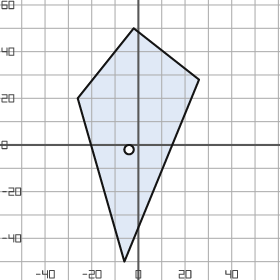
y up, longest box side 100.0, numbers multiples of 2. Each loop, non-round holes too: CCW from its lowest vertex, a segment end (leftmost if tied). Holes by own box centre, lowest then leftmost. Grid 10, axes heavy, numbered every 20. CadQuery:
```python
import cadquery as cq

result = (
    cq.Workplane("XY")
    .moveTo(-6.0, -50.0)
    .lineTo(26.0, 28.0)
    .lineTo(-2.0, 50.0)
    .lineTo(-26.0, 20.0)
    .close()
    .moveTo(-4.0, -2.0)
    .circle(2.0)
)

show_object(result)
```